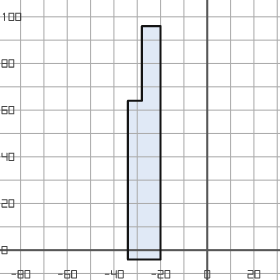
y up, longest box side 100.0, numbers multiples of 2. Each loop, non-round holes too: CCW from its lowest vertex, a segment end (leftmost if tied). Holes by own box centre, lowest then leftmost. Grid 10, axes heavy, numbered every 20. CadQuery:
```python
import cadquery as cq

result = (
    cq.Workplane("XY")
    .moveTo(-34.0, -4.0)
    .lineTo(-20.0, -4.0)
    .lineTo(-20.0, 96.0)
    .lineTo(-28.0, 96.0)
    .lineTo(-28.0, 64.0)
    .lineTo(-34.0, 64.0)
    .close()
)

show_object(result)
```